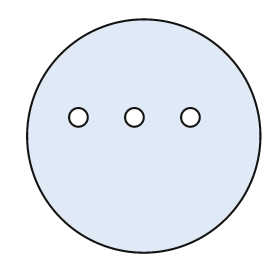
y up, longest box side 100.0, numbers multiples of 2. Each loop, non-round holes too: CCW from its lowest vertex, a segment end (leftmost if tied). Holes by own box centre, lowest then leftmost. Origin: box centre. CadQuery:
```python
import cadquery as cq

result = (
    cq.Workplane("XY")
    .moveTo(0.0, 0.0)
    .circle(50.0)
    .moveTo(-28.0, 8.0)
    .circle(4.0)
    .moveTo(-4.0, 8.0)
    .circle(4.0)
    .moveTo(20.0, 8.0)
    .circle(4.0)
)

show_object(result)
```